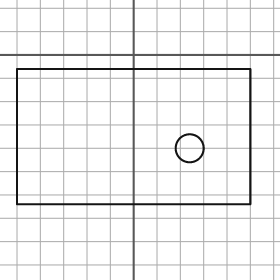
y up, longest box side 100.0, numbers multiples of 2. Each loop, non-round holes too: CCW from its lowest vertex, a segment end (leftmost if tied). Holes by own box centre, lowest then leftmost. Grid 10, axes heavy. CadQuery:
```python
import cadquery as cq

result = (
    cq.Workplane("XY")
    .moveTo(-50.0, -64.0)
    .lineTo(50.0, -64.0)
    .lineTo(50.0, -6.0)
    .lineTo(-50.0, -6.0)
    .close()
    .moveTo(24.0, -40.0)
    .circle(6.0)
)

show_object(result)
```